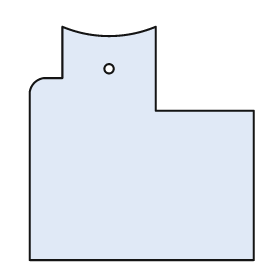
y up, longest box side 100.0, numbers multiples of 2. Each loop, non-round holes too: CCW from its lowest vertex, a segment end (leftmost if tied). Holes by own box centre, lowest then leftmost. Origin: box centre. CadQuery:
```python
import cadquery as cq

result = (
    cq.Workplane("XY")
    .moveTo(-48.0, -50.0)
    .lineTo(48.0, -50.0)
    .lineTo(48.0, 14.0)
    .lineTo(6.0, 14.0)
    .lineTo(6.0, 50.0)
    .threePointArc((-14.0, 46.0), (-34.0, 50.0))
    .lineTo(-34.0, 28.0)
    .lineTo(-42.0, 28.0)
    .threePointArc((-46.0, 26.0), (-48.0, 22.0))
    .close()
    .moveTo(-14.0, 32.0)
    .circle(2.0)
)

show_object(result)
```